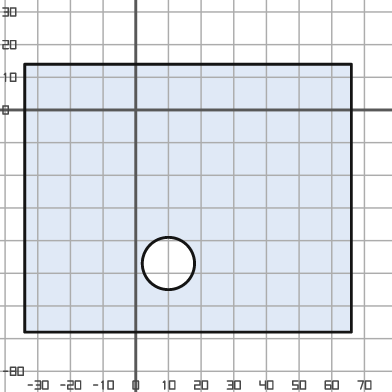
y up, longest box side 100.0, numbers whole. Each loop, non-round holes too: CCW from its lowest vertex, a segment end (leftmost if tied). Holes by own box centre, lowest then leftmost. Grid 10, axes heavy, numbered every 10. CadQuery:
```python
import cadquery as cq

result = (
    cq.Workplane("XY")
    .moveTo(-34.0, -68.0)
    .lineTo(66.0, -68.0)
    .lineTo(66.0, 14.0)
    .lineTo(-34.0, 14.0)
    .close()
    .moveTo(10.0, -47.0)
    .circle(8.0)
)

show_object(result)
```